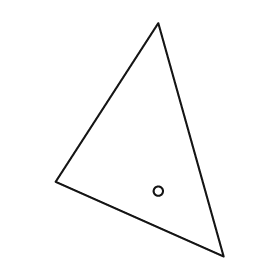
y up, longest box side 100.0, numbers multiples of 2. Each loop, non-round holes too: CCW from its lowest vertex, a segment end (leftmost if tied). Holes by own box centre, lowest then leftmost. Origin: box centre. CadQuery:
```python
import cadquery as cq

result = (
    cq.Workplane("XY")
    .moveTo(36.0, -50.0)
    .lineTo(8.0, 50.0)
    .lineTo(-36.0, -18.0)
    .close()
    .moveTo(8.0, -22.0)
    .circle(2.0)
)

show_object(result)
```